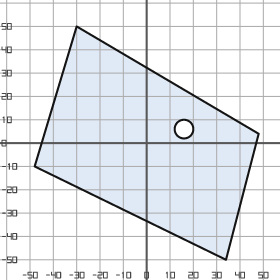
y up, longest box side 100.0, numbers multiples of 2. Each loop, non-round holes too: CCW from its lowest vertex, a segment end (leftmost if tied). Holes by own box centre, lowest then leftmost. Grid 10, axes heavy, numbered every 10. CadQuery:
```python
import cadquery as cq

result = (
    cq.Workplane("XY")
    .moveTo(34.0, -50.0)
    .lineTo(48.0, 4.0)
    .lineTo(-30.0, 50.0)
    .lineTo(-48.0, -10.0)
    .close()
    .moveTo(16.0, 6.0)
    .circle(4.0)
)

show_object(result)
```